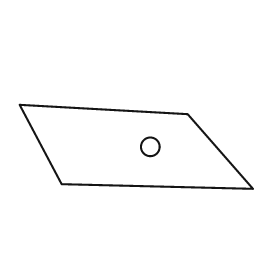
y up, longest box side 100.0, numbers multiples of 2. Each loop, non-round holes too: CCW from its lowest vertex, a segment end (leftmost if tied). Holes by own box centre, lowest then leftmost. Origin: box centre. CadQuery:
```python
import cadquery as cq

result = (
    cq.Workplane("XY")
    .moveTo(50.0, -18.0)
    .lineTo(22.0, 14.0)
    .lineTo(-50.0, 18.0)
    .lineTo(-32.0, -16.0)
    .close()
    .moveTo(6.0, 0.0)
    .circle(4.0)
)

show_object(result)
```